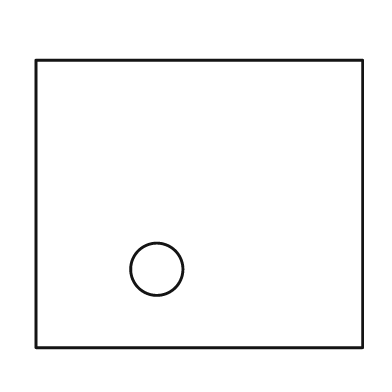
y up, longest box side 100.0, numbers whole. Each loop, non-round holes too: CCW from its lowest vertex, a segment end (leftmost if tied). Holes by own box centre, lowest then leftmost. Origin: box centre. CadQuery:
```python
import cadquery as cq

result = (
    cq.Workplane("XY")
    .moveTo(-50.0, -44.0)
    .lineTo(50.0, -44.0)
    .lineTo(50.0, 44.0)
    .lineTo(-50.0, 44.0)
    .close()
    .moveTo(-13.0, -20.0)
    .circle(8.0)
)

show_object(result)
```